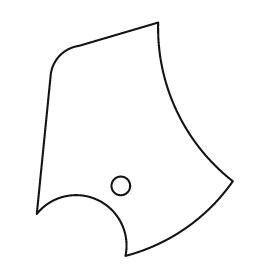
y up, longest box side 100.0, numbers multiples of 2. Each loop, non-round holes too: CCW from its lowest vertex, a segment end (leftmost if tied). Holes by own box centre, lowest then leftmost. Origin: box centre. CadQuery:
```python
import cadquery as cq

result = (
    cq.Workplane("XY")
    .moveTo(-4.0, -50.0)
    .threePointArc((22.0, -38.0), (42.0, -18.0))
    .threePointArc((18.0, 12.0), (10.0, 50.0))
    .lineTo(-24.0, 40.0)
    .threePointArc((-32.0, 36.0), (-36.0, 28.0))
    .lineTo(-42.0, -32.0)
    .threePointArc((-16.0, -26.0), (-4.0, -50.0))
    .close()
    .moveTo(-6.0, -20.0)
    .circle(4.0)
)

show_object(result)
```